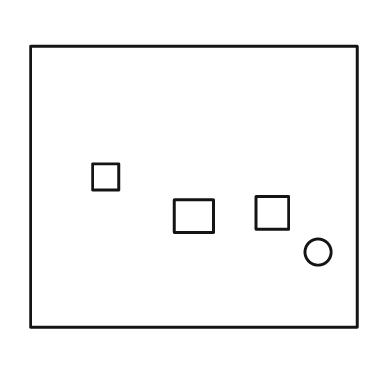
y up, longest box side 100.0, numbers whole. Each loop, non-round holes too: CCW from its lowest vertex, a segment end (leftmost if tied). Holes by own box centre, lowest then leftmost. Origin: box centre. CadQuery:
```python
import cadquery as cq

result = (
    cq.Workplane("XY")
    .moveTo(-50.0, -43.0)
    .lineTo(50.0, -43.0)
    .lineTo(50.0, 43.0)
    .lineTo(-50.0, 43.0)
    .close()
    .moveTo(38.0, -20.0)
    .circle(4.0)
    .moveTo(-6.0, -14.0)
    .lineTo(6.0, -14.0)
    .lineTo(6.0, -4.0)
    .lineTo(-6.0, -4.0)
    .close()
    .moveTo(19.0, -13.0)
    .lineTo(29.0, -13.0)
    .lineTo(29.0, -3.0)
    .lineTo(19.0, -3.0)
    .close()
    .moveTo(-31.0, -1.0)
    .lineTo(-23.0, -1.0)
    .lineTo(-23.0, 7.0)
    .lineTo(-31.0, 7.0)
    .close()
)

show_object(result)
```